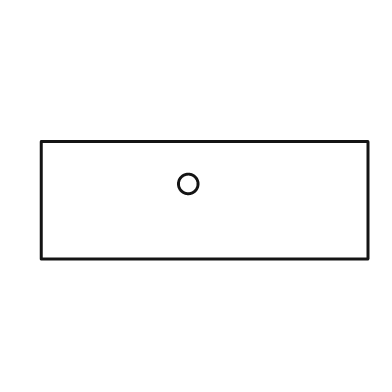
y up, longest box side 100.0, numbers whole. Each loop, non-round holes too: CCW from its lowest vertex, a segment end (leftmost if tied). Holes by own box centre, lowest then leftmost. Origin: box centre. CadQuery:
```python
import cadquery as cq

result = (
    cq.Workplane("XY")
    .moveTo(-50.0, -18.0)
    .lineTo(50.0, -18.0)
    .lineTo(50.0, 18.0)
    .lineTo(-50.0, 18.0)
    .close()
    .moveTo(-5.0, 5.0)
    .circle(3.0)
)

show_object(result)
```